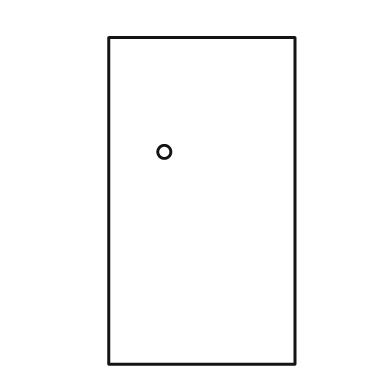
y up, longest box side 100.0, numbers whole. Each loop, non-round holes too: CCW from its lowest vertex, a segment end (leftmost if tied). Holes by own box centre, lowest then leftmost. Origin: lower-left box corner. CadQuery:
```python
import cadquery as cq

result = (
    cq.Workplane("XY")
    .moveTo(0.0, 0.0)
    .lineTo(57.0, 0.0)
    .lineTo(57.0, 100.0)
    .lineTo(0.0, 100.0)
    .close()
    .moveTo(17.0, 65.0)
    .circle(2.0)
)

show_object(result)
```